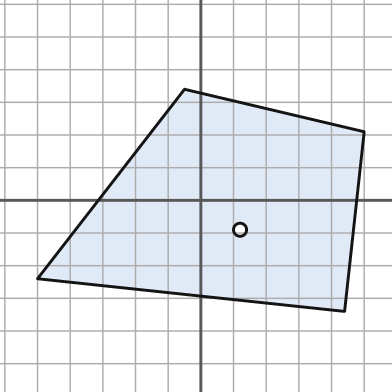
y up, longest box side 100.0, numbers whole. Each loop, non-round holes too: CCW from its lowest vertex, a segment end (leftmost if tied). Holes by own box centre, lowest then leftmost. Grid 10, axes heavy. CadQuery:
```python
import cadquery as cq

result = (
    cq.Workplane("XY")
    .moveTo(44.0, -34.0)
    .lineTo(50.0, 21.0)
    .lineTo(-5.0, 34.0)
    .lineTo(-50.0, -24.0)
    .close()
    .moveTo(12.0, -9.0)
    .circle(2.0)
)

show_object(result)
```